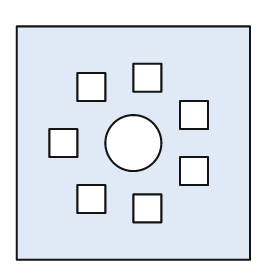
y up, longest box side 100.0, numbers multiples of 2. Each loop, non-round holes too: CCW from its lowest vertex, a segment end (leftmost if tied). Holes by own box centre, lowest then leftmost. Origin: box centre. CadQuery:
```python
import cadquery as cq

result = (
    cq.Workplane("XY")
    .moveTo(-50.0, -50.0)
    .lineTo(50.0, -50.0)
    .lineTo(50.0, 50.0)
    .lineTo(-50.0, 50.0)
    .close()
    .moveTo(0.0, -34.0)
    .lineTo(12.0, -34.0)
    .lineTo(12.0, -22.0)
    .lineTo(0.0, -22.0)
    .close()
    .moveTo(-24.0, -30.0)
    .lineTo(-12.0, -30.0)
    .lineTo(-12.0, -18.0)
    .lineTo(-24.0, -18.0)
    .close()
    .moveTo(20.0, -18.0)
    .lineTo(32.0, -18.0)
    .lineTo(32.0, -6.0)
    .lineTo(20.0, -6.0)
    .close()
    .moveTo(-36.0, -6.0)
    .lineTo(-24.0, -6.0)
    .lineTo(-24.0, 6.0)
    .lineTo(-36.0, 6.0)
    .close()
    .moveTo(0.0, 0.0)
    .circle(12.0)
    .moveTo(20.0, 6.0)
    .lineTo(32.0, 6.0)
    .lineTo(32.0, 18.0)
    .lineTo(20.0, 18.0)
    .close()
    .moveTo(-24.0, 18.0)
    .lineTo(-12.0, 18.0)
    .lineTo(-12.0, 30.0)
    .lineTo(-24.0, 30.0)
    .close()
    .moveTo(0.0, 22.0)
    .lineTo(12.0, 22.0)
    .lineTo(12.0, 34.0)
    .lineTo(0.0, 34.0)
    .close()
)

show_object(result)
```